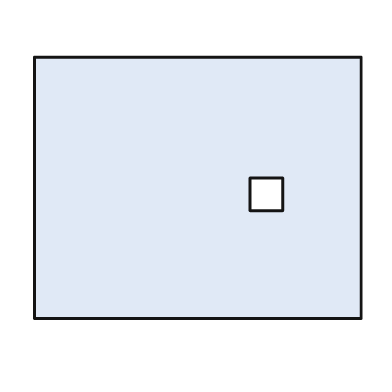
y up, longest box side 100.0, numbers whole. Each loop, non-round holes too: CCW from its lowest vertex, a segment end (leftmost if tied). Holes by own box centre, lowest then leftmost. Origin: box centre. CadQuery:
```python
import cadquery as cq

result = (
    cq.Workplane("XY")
    .moveTo(-50.0, -40.0)
    .lineTo(50.0, -40.0)
    .lineTo(50.0, 40.0)
    .lineTo(-50.0, 40.0)
    .close()
    .moveTo(16.0, -7.0)
    .lineTo(26.0, -7.0)
    .lineTo(26.0, 3.0)
    .lineTo(16.0, 3.0)
    .close()
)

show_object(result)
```